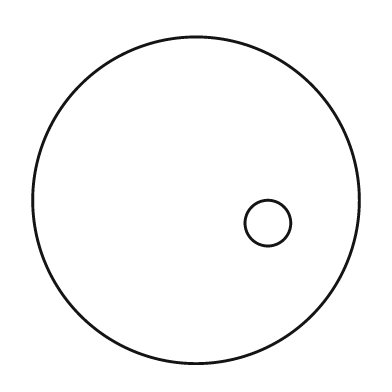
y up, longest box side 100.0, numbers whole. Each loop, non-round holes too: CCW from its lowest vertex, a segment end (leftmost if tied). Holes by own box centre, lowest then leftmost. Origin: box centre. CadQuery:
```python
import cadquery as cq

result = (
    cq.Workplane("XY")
    .moveTo(0.0, 0.0)
    .circle(50.0)
    .moveTo(22.0, -7.0)
    .circle(7.0)
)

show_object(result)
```